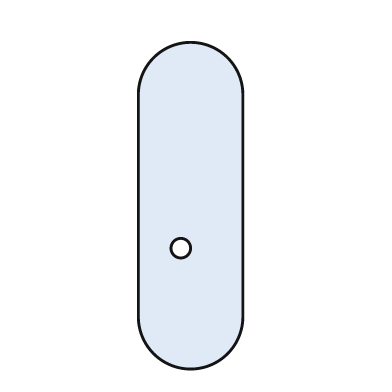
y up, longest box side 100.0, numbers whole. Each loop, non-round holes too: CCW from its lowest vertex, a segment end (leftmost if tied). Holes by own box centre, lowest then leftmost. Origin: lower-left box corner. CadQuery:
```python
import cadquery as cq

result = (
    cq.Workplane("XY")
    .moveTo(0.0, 16.0)
    .threePointArc((16.0, 0.0), (32.0, 16.0))
    .lineTo(32.0, 84.0)
    .threePointArc((16.0, 100.0), (0.0, 84.0))
    .close()
    .moveTo(13.0, 37.0)
    .circle(3.0)
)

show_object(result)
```